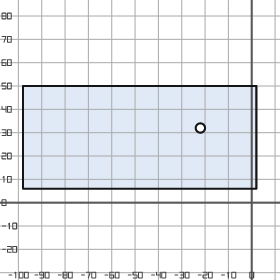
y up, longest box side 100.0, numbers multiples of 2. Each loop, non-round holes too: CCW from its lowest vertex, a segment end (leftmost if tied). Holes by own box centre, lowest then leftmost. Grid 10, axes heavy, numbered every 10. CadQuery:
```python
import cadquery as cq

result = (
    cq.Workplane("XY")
    .moveTo(-98.0, 6.0)
    .lineTo(2.0, 6.0)
    .lineTo(2.0, 50.0)
    .lineTo(-98.0, 50.0)
    .close()
    .moveTo(-22.0, 32.0)
    .circle(2.0)
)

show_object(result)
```